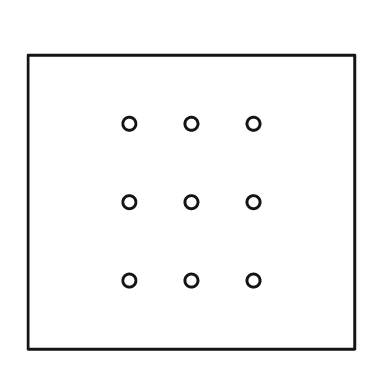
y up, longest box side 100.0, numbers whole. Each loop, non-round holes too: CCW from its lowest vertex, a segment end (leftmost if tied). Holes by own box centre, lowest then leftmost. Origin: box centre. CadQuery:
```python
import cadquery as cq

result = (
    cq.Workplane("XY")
    .moveTo(-50.0, -45.0)
    .lineTo(50.0, -45.0)
    .lineTo(50.0, 45.0)
    .lineTo(-50.0, 45.0)
    .close()
    .moveTo(-19.0, -24.0)
    .circle(2.0)
    .moveTo(0.0, -24.0)
    .circle(2.0)
    .moveTo(19.0, -24.0)
    .circle(2.0)
    .moveTo(-19.0, 0.0)
    .circle(2.0)
    .moveTo(0.0, 0.0)
    .circle(2.0)
    .moveTo(19.0, 0.0)
    .circle(2.0)
    .moveTo(-19.0, 24.0)
    .circle(2.0)
    .moveTo(0.0, 24.0)
    .circle(2.0)
    .moveTo(19.0, 24.0)
    .circle(2.0)
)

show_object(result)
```